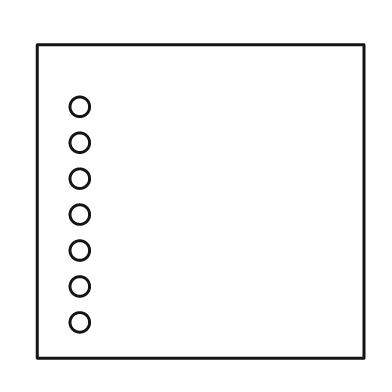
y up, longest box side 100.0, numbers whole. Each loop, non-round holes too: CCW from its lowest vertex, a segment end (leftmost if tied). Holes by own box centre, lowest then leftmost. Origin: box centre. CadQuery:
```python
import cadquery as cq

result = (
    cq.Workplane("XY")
    .moveTo(-50.0, -48.0)
    .lineTo(50.0, -48.0)
    .lineTo(50.0, 48.0)
    .lineTo(-50.0, 48.0)
    .close()
    .moveTo(-37.0, -37.0)
    .circle(3.0)
    .moveTo(-37.0, -26.0)
    .circle(3.0)
    .moveTo(-37.0, -15.0)
    .circle(3.0)
    .moveTo(-37.0, -4.0)
    .circle(3.0)
    .moveTo(-37.0, 7.0)
    .circle(3.0)
    .moveTo(-37.0, 18.0)
    .circle(3.0)
    .moveTo(-37.0, 29.0)
    .circle(3.0)
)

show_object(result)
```